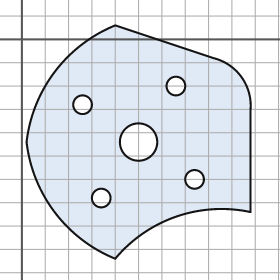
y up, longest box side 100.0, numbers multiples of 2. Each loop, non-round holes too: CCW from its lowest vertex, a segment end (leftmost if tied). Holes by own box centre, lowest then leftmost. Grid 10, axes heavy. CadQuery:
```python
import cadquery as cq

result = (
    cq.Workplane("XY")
    .moveTo(40.0, -94.0)
    .threePointArc((66.0, -76.0), (98.0, -74.0))
    .lineTo(98.0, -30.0)
    .threePointArc((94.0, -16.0), (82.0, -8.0))
    .lineTo(40.0, 6.0)
    .threePointArc((14.0, -14.0), (2.0, -44.0))
    .threePointArc((14.0, -74.0), (40.0, -94.0))
    .close()
    .moveTo(34.0, -68.0)
    .circle(4.0)
    .moveTo(74.0, -60.0)
    .circle(4.0)
    .moveTo(50.0, -44.0)
    .circle(8.0)
    .moveTo(26.0, -28.0)
    .circle(4.0)
    .moveTo(66.0, -20.0)
    .circle(4.0)
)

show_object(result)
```